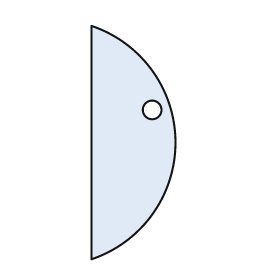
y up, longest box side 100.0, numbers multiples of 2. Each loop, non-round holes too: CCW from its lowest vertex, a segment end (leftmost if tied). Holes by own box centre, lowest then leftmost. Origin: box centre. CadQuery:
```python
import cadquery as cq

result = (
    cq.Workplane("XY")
    .moveTo(-18.0, -50.0)
    .threePointArc((18.0, 0.0), (-18.0, 50.0))
    .close()
    .moveTo(8.0, 14.0)
    .circle(4.0)
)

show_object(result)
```